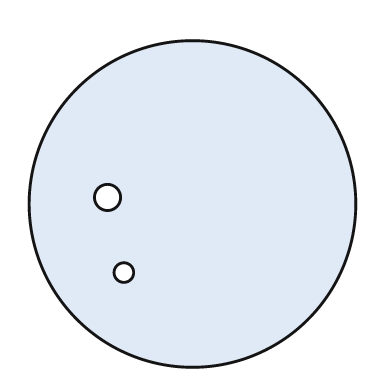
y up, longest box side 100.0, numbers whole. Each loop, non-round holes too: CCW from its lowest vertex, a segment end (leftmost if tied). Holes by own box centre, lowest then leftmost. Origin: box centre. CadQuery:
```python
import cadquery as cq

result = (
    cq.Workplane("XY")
    .moveTo(0.0, 0.0)
    .circle(50.0)
    .moveTo(-21.0, -21.0)
    .circle(3.0)
    .moveTo(-26.0, 2.0)
    .circle(4.0)
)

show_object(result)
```